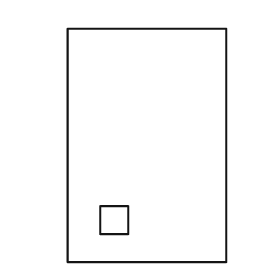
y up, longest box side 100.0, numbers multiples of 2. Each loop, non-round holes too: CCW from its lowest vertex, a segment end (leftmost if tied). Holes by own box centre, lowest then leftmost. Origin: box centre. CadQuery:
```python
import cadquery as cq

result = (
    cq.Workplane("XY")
    .moveTo(-34.0, -50.0)
    .lineTo(34.0, -50.0)
    .lineTo(34.0, 50.0)
    .lineTo(-34.0, 50.0)
    .close()
    .moveTo(-20.0, -38.0)
    .lineTo(-8.0, -38.0)
    .lineTo(-8.0, -26.0)
    .lineTo(-20.0, -26.0)
    .close()
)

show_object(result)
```